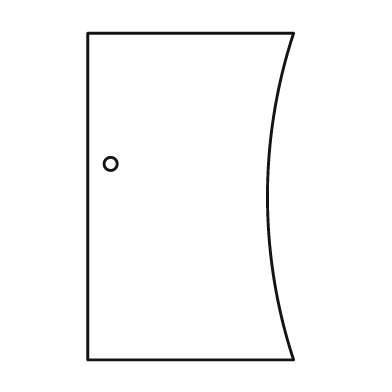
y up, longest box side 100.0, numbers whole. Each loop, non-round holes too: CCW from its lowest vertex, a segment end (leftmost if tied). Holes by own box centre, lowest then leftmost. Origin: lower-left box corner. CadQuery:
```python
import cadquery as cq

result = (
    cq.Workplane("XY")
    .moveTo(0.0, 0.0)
    .lineTo(63.0, 0.0)
    .threePointArc((55.0, 50.0), (63.0, 100.0))
    .lineTo(0.0, 100.0)
    .close()
    .moveTo(7.0, 60.0)
    .circle(2.0)
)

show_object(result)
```